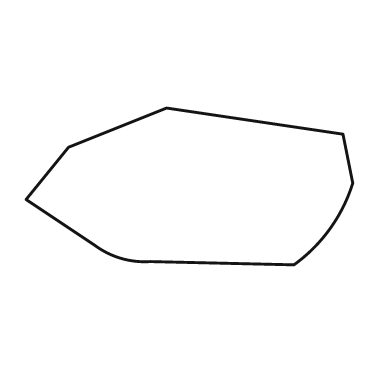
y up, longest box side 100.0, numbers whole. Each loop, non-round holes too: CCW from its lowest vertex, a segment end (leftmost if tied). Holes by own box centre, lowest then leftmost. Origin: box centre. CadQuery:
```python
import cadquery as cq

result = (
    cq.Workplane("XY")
    .moveTo(32.0, -24.0)
    .threePointArc((43.0, -13.0), (50.0, 1.0))
    .lineTo(47.0, 16.0)
    .lineTo(-7.0, 24.0)
    .lineTo(-37.0, 12.0)
    .lineTo(-50.0, -4.0)
    .lineTo(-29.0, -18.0)
    .threePointArc((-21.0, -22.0), (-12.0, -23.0))
    .close()
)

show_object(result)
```